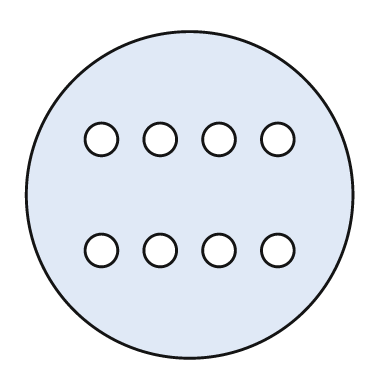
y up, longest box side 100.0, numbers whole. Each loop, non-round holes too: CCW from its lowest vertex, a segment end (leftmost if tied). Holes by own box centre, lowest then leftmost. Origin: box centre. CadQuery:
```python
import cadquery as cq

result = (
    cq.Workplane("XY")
    .moveTo(0.0, 0.0)
    .circle(50.0)
    .moveTo(-27.0, -17.0)
    .circle(5.0)
    .moveTo(-9.0, -17.0)
    .circle(5.0)
    .moveTo(9.0, -17.0)
    .circle(5.0)
    .moveTo(27.0, -17.0)
    .circle(5.0)
    .moveTo(-27.0, 17.0)
    .circle(5.0)
    .moveTo(-9.0, 17.0)
    .circle(5.0)
    .moveTo(9.0, 17.0)
    .circle(5.0)
    .moveTo(27.0, 17.0)
    .circle(5.0)
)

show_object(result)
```